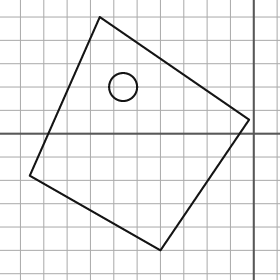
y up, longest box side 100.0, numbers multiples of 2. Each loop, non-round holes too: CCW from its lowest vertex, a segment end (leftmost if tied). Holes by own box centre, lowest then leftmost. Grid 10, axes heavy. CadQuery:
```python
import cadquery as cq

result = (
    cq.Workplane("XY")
    .moveTo(-40.0, -50.0)
    .lineTo(-2.0, 6.0)
    .lineTo(-66.0, 50.0)
    .lineTo(-96.0, -18.0)
    .close()
    .moveTo(-56.0, 20.0)
    .circle(6.0)
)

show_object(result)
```